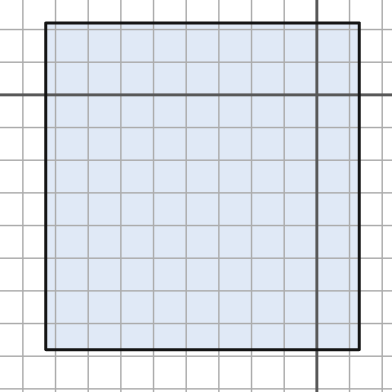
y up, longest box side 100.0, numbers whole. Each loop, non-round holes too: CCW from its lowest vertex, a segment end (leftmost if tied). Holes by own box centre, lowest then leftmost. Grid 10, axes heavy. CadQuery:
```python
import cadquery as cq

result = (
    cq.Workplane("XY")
    .moveTo(-83.0, -78.0)
    .lineTo(13.0, -78.0)
    .lineTo(13.0, 22.0)
    .lineTo(-83.0, 22.0)
    .close()
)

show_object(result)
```